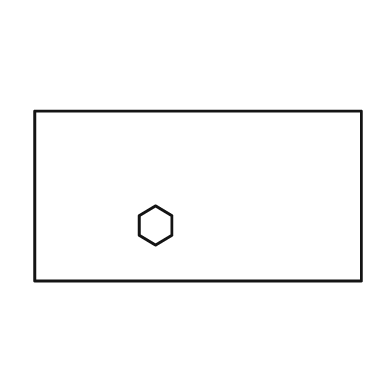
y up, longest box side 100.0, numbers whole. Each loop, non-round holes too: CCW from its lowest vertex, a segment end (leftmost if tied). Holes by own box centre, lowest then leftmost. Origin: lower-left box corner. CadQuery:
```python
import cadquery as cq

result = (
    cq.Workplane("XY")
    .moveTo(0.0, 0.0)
    .lineTo(100.0, 0.0)
    .lineTo(100.0, 52.0)
    .lineTo(0.0, 52.0)
    .close()
    .moveTo(37.0, 11.0)
    .lineTo(42.0, 14.0)
    .lineTo(42.0, 20.0)
    .lineTo(37.0, 23.0)
    .lineTo(32.0, 20.0)
    .lineTo(32.0, 14.0)
    .close()
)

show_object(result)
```